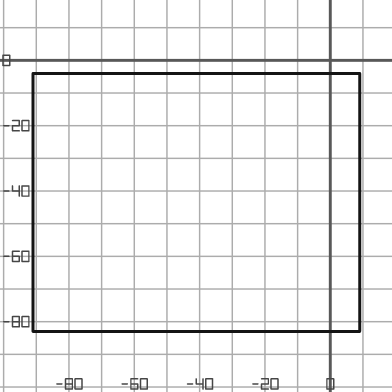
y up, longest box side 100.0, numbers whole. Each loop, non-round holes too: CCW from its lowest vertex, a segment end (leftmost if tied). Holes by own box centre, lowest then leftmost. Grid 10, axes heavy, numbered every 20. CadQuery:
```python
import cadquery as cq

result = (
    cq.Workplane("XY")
    .moveTo(-91.0, -83.0)
    .lineTo(9.0, -83.0)
    .lineTo(9.0, -4.0)
    .lineTo(-91.0, -4.0)
    .close()
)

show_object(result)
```